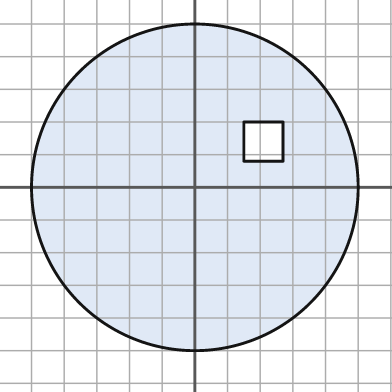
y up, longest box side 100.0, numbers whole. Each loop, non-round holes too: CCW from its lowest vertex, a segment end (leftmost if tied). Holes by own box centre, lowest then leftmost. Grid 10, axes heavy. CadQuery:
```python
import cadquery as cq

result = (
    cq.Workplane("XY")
    .moveTo(0.0, 0.0)
    .circle(50.0)
    .moveTo(15.0, 8.0)
    .lineTo(27.0, 8.0)
    .lineTo(27.0, 20.0)
    .lineTo(15.0, 20.0)
    .close()
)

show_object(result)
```